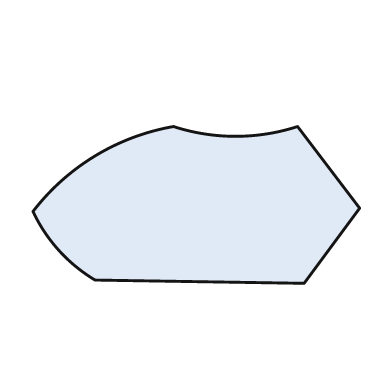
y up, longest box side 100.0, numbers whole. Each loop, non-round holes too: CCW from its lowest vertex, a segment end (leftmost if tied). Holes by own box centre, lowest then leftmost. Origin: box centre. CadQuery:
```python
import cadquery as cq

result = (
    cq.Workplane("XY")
    .moveTo(33.0, -24.0)
    .lineTo(50.0, -1.0)
    .lineTo(31.0, 24.0)
    .threePointArc((12.0, 21.0), (-7.0, 24.0))
    .threePointArc((-31.0, 15.0), (-50.0, -2.0))
    .threePointArc((-42.0, -14.0), (-31.0, -23.0))
    .close()
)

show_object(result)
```